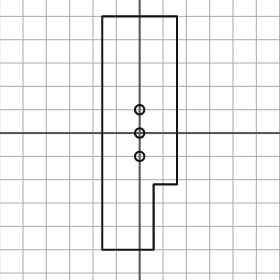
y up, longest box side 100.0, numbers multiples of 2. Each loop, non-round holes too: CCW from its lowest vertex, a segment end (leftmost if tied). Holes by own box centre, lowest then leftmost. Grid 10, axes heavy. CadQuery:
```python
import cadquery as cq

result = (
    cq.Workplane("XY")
    .moveTo(-16.0, -50.0)
    .lineTo(6.0, -50.0)
    .lineTo(6.0, -22.0)
    .lineTo(16.0, -22.0)
    .lineTo(16.0, 50.0)
    .lineTo(-16.0, 50.0)
    .close()
    .moveTo(0.0, -10.0)
    .circle(2.0)
    .moveTo(0.0, 0.0)
    .circle(2.0)
    .moveTo(0.0, 10.0)
    .circle(2.0)
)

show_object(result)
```